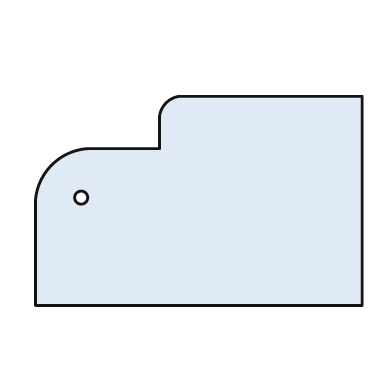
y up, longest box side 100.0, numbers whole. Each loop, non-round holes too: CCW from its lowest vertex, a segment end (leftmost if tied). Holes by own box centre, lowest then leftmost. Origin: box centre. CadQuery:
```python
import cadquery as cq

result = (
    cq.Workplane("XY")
    .moveTo(-50.0, -32.0)
    .lineTo(50.0, -32.0)
    .lineTo(50.0, 32.0)
    .lineTo(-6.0, 32.0)
    .threePointArc((-10.0, 30.0), (-12.0, 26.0))
    .lineTo(-12.0, 16.0)
    .lineTo(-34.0, 16.0)
    .threePointArc((-45.0, 11.0), (-50.0, 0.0))
    .close()
    .moveTo(-36.0, 1.0)
    .circle(2.0)
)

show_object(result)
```